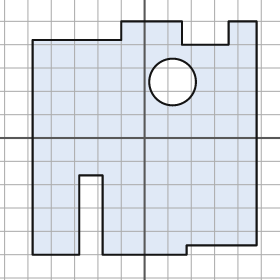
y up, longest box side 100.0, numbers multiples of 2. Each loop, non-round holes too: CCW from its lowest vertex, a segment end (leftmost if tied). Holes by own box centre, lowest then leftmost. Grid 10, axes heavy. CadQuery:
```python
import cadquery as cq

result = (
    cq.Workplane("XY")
    .moveTo(-48.0, -50.0)
    .lineTo(-28.0, -50.0)
    .lineTo(-28.0, -16.0)
    .lineTo(-18.0, -16.0)
    .lineTo(-18.0, -50.0)
    .lineTo(18.0, -50.0)
    .lineTo(18.0, -46.0)
    .lineTo(48.0, -46.0)
    .lineTo(48.0, 50.0)
    .lineTo(36.0, 50.0)
    .lineTo(36.0, 40.0)
    .lineTo(16.0, 40.0)
    .lineTo(16.0, 50.0)
    .lineTo(-10.0, 50.0)
    .lineTo(-10.0, 42.0)
    .lineTo(-48.0, 42.0)
    .close()
    .moveTo(12.0, 24.0)
    .circle(10.0)
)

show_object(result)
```